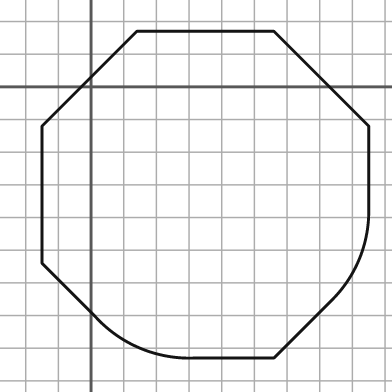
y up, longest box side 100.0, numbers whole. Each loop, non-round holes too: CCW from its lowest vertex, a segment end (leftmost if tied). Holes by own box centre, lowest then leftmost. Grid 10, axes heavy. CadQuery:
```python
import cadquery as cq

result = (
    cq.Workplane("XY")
    .moveTo(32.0, -83.0)
    .lineTo(56.0, -83.0)
    .lineTo(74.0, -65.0)
    .threePointArc((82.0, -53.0), (85.0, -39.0))
    .lineTo(85.0, -12.0)
    .lineTo(56.0, 17.0)
    .lineTo(14.0, 17.0)
    .lineTo(-15.0, -12.0)
    .lineTo(-15.0, -54.0)
    .lineTo(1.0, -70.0)
    .threePointArc((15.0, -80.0), (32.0, -83.0))
    .close()
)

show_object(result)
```